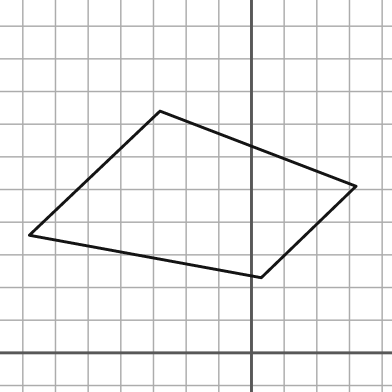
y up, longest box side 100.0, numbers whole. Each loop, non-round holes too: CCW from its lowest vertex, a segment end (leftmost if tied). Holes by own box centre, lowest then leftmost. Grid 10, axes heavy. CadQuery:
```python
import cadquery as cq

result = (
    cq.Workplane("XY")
    .moveTo(3.0, 23.0)
    .lineTo(32.0, 51.0)
    .lineTo(-28.0, 74.0)
    .lineTo(-68.0, 36.0)
    .close()
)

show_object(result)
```